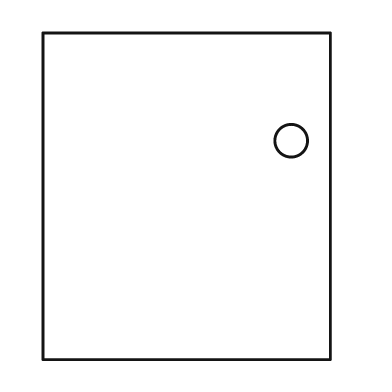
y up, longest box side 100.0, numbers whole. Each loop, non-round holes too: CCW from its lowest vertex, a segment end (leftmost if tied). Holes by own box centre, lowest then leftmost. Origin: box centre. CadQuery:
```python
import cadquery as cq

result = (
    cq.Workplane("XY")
    .moveTo(-44.0, -50.0)
    .lineTo(44.0, -50.0)
    .lineTo(44.0, 50.0)
    .lineTo(-44.0, 50.0)
    .close()
    .moveTo(32.0, 17.0)
    .circle(5.0)
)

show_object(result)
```